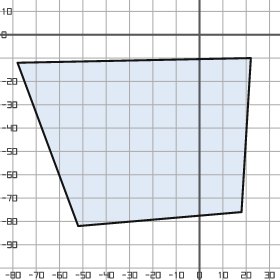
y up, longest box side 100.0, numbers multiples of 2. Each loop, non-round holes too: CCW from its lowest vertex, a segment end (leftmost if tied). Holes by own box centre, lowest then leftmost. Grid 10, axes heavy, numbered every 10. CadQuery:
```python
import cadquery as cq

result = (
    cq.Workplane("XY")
    .moveTo(-52.0, -82.0)
    .lineTo(18.0, -76.0)
    .lineTo(22.0, -10.0)
    .lineTo(-78.0, -12.0)
    .close()
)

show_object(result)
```